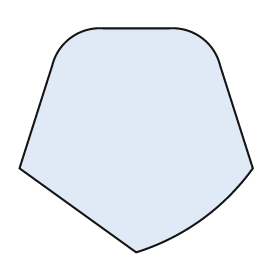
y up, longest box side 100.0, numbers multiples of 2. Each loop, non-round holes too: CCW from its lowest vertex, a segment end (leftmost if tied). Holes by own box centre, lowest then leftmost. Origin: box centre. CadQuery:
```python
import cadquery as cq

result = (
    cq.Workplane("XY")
    .moveTo(0.0, -48.0)
    .threePointArc((28.0, -34.0), (50.0, -12.0))
    .lineTo(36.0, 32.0)
    .threePointArc((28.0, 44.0), (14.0, 48.0))
    .lineTo(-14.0, 48.0)
    .threePointArc((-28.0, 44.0), (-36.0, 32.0))
    .lineTo(-50.0, -12.0)
    .close()
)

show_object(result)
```